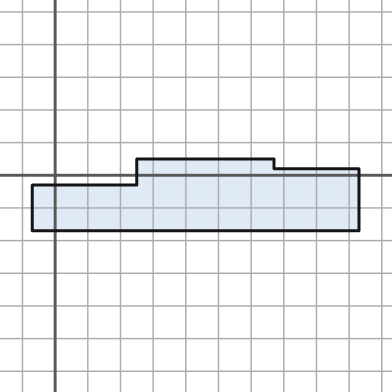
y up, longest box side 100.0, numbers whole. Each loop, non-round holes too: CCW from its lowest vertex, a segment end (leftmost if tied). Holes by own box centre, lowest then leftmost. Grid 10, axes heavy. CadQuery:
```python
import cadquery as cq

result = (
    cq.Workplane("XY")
    .moveTo(-7.0, -17.0)
    .lineTo(93.0, -17.0)
    .lineTo(93.0, 2.0)
    .lineTo(67.0, 2.0)
    .lineTo(67.0, 5.0)
    .lineTo(25.0, 5.0)
    .lineTo(25.0, -3.0)
    .lineTo(-7.0, -3.0)
    .close()
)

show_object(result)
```